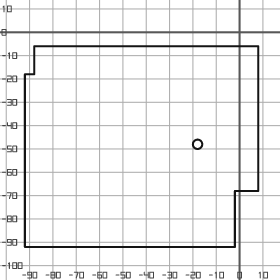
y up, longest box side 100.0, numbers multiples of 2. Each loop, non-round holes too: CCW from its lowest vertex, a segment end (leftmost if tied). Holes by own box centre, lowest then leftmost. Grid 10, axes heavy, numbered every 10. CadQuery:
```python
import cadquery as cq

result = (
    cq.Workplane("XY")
    .moveTo(-92.0, -92.0)
    .lineTo(-2.0, -92.0)
    .lineTo(-2.0, -68.0)
    .lineTo(8.0, -68.0)
    .lineTo(8.0, -6.0)
    .lineTo(-88.0, -6.0)
    .lineTo(-88.0, -18.0)
    .lineTo(-92.0, -18.0)
    .close()
    .moveTo(-18.0, -48.0)
    .circle(2.0)
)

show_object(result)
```